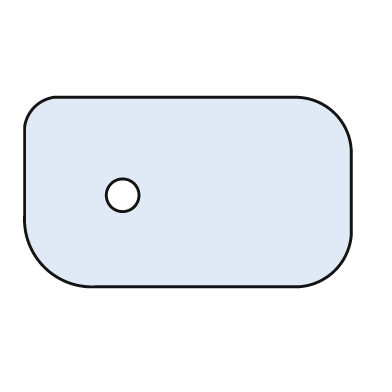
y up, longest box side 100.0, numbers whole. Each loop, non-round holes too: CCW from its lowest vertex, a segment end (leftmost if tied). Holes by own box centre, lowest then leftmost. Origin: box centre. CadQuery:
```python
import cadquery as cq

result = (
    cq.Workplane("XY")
    .moveTo(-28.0, -29.0)
    .lineTo(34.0, -29.0)
    .threePointArc((45.0, -24.0), (50.0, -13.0))
    .lineTo(50.0, 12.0)
    .threePointArc((45.0, 24.0), (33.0, 29.0))
    .lineTo(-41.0, 29.0)
    .threePointArc((-47.0, 26.0), (-50.0, 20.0))
    .lineTo(-50.0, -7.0)
    .threePointArc((-44.0, -23.0), (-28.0, -29.0))
    .close()
    .moveTo(-20.0, -1.0)
    .circle(5.0)
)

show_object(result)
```